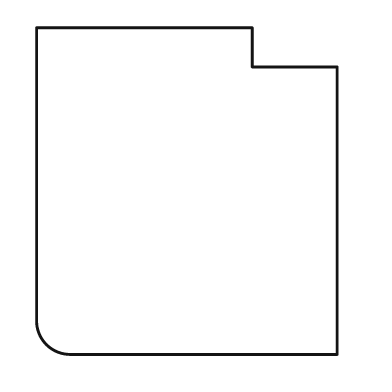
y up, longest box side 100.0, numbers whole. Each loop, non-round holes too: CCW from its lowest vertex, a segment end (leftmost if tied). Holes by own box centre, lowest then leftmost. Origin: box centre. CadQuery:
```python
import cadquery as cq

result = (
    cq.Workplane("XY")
    .moveTo(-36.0, -50.0)
    .lineTo(46.0, -50.0)
    .lineTo(46.0, 38.0)
    .lineTo(20.0, 38.0)
    .lineTo(20.0, 50.0)
    .lineTo(-46.0, 50.0)
    .lineTo(-46.0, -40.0)
    .threePointArc((-43.0, -47.0), (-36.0, -50.0))
    .close()
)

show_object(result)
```